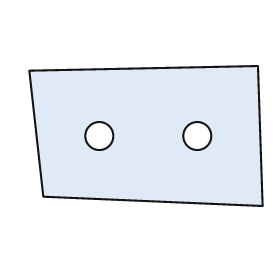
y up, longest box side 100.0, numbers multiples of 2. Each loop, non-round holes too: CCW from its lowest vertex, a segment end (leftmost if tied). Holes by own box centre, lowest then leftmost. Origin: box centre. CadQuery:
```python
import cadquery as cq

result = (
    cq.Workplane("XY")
    .moveTo(50.0, -30.0)
    .lineTo(48.0, 30.0)
    .lineTo(-50.0, 28.0)
    .lineTo(-44.0, -26.0)
    .close()
    .moveTo(-20.0, 0.0)
    .circle(6.0)
    .moveTo(22.0, 0.0)
    .circle(6.0)
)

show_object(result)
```